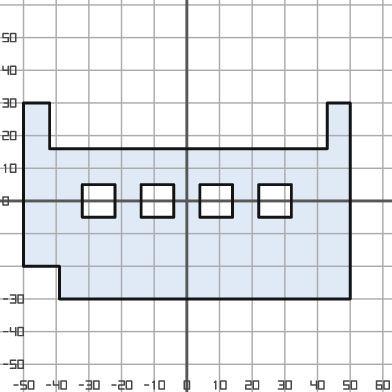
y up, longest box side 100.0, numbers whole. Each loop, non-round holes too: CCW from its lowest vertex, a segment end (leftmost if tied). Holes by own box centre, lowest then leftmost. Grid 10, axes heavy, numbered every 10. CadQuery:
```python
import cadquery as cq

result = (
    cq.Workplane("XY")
    .moveTo(-39.0, -30.0)
    .lineTo(50.0, -30.0)
    .lineTo(50.0, 30.0)
    .lineTo(43.0, 30.0)
    .lineTo(43.0, 16.0)
    .lineTo(-42.0, 16.0)
    .lineTo(-42.0, 30.0)
    .lineTo(-50.0, 30.0)
    .lineTo(-50.0, -20.0)
    .lineTo(-39.0, -20.0)
    .close()
    .moveTo(-32.0, -5.0)
    .lineTo(-22.0, -5.0)
    .lineTo(-22.0, 5.0)
    .lineTo(-32.0, 5.0)
    .close()
    .moveTo(-14.0, -5.0)
    .lineTo(-4.0, -5.0)
    .lineTo(-4.0, 5.0)
    .lineTo(-14.0, 5.0)
    .close()
    .moveTo(4.0, -5.0)
    .lineTo(14.0, -5.0)
    .lineTo(14.0, 5.0)
    .lineTo(4.0, 5.0)
    .close()
    .moveTo(22.0, -5.0)
    .lineTo(32.0, -5.0)
    .lineTo(32.0, 5.0)
    .lineTo(22.0, 5.0)
    .close()
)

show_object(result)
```